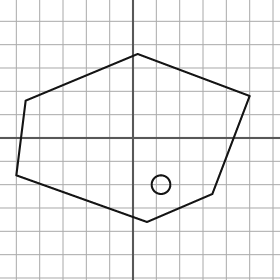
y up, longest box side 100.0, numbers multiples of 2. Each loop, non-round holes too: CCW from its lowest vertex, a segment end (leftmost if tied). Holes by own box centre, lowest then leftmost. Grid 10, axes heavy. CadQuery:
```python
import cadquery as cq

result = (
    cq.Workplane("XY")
    .moveTo(6.0, -36.0)
    .lineTo(34.0, -24.0)
    .lineTo(50.0, 18.0)
    .lineTo(2.0, 36.0)
    .lineTo(-46.0, 16.0)
    .lineTo(-50.0, -16.0)
    .close()
    .moveTo(12.0, -20.0)
    .circle(4.0)
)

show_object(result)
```